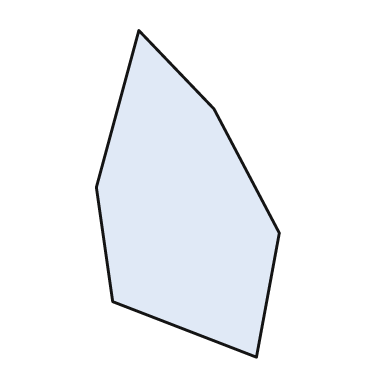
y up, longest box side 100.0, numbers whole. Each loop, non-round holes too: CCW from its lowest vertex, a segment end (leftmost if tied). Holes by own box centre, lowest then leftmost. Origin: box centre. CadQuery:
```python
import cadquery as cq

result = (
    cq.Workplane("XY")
    .moveTo(21.0, -50.0)
    .lineTo(28.0, -12.0)
    .lineTo(8.0, 26.0)
    .lineTo(-15.0, 50.0)
    .lineTo(-28.0, 2.0)
    .lineTo(-23.0, -33.0)
    .close()
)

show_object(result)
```